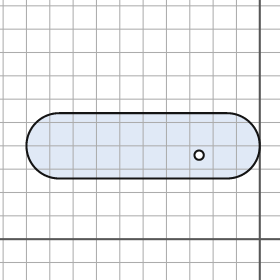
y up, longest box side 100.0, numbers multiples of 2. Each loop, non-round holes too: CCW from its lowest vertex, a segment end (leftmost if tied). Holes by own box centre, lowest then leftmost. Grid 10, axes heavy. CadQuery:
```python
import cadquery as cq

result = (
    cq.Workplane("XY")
    .moveTo(-86.0, 26.0)
    .lineTo(-14.0, 26.0)
    .threePointArc((0.0, 40.0), (-14.0, 54.0))
    .lineTo(-86.0, 54.0)
    .threePointArc((-100.0, 40.0), (-86.0, 26.0))
    .close()
    .moveTo(-26.0, 36.0)
    .circle(2.0)
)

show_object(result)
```